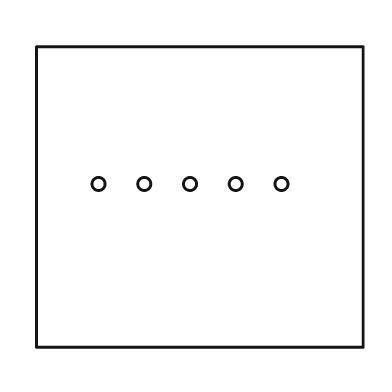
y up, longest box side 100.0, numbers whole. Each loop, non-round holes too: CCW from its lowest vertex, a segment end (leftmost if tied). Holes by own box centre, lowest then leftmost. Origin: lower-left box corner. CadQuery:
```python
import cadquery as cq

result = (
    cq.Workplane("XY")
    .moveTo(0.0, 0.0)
    .lineTo(100.0, 0.0)
    .lineTo(100.0, 92.0)
    .lineTo(0.0, 92.0)
    .close()
    .moveTo(19.0, 50.0)
    .circle(2.0)
    .moveTo(33.0, 50.0)
    .circle(2.0)
    .moveTo(47.0, 50.0)
    .circle(2.0)
    .moveTo(61.0, 50.0)
    .circle(2.0)
    .moveTo(75.0, 50.0)
    .circle(2.0)
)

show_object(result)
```